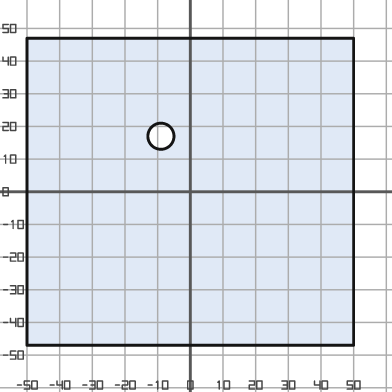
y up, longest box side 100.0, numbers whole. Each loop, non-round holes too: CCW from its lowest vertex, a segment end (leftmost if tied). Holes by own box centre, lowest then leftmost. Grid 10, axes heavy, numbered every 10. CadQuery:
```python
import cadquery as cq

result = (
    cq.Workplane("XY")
    .moveTo(-50.0, -47.0)
    .lineTo(50.0, -47.0)
    .lineTo(50.0, 47.0)
    .lineTo(-50.0, 47.0)
    .close()
    .moveTo(-9.0, 17.0)
    .circle(4.0)
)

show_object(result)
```